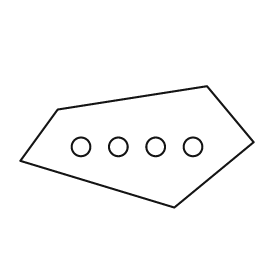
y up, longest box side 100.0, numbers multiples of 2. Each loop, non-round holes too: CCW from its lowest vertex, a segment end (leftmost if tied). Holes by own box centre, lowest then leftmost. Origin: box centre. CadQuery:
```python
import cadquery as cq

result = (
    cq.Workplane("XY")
    .moveTo(16.0, -26.0)
    .lineTo(50.0, 2.0)
    .lineTo(30.0, 26.0)
    .lineTo(-34.0, 16.0)
    .lineTo(-50.0, -6.0)
    .close()
    .moveTo(-24.0, 0.0)
    .circle(4.0)
    .moveTo(-8.0, 0.0)
    .circle(4.0)
    .moveTo(8.0, 0.0)
    .circle(4.0)
    .moveTo(24.0, 0.0)
    .circle(4.0)
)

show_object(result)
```